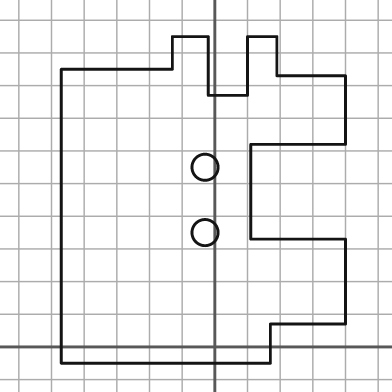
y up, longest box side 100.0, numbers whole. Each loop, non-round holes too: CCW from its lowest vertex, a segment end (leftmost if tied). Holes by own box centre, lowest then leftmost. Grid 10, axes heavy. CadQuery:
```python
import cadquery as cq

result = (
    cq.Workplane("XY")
    .moveTo(-47.0, -5.0)
    .lineTo(17.0, -5.0)
    .lineTo(17.0, 7.0)
    .lineTo(40.0, 7.0)
    .lineTo(40.0, 33.0)
    .lineTo(11.0, 33.0)
    .lineTo(11.0, 62.0)
    .lineTo(40.0, 62.0)
    .lineTo(40.0, 83.0)
    .lineTo(19.0, 83.0)
    .lineTo(19.0, 95.0)
    .lineTo(10.0, 95.0)
    .lineTo(10.0, 77.0)
    .lineTo(-2.0, 77.0)
    .lineTo(-2.0, 95.0)
    .lineTo(-13.0, 95.0)
    .lineTo(-13.0, 85.0)
    .lineTo(-47.0, 85.0)
    .close()
    .moveTo(-3.0, 35.0)
    .circle(4.0)
    .moveTo(-3.0, 55.0)
    .circle(4.0)
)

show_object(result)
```